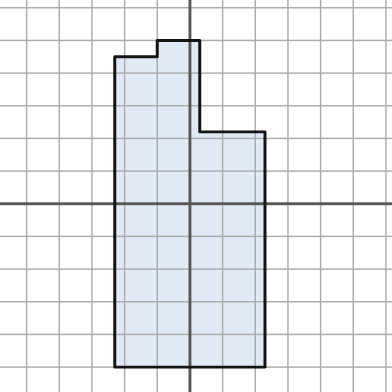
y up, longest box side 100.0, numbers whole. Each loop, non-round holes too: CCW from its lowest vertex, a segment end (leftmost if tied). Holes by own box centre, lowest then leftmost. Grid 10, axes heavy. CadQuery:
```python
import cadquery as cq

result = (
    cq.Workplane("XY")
    .moveTo(-23.0, -50.0)
    .lineTo(23.0, -50.0)
    .lineTo(23.0, 22.0)
    .lineTo(3.0, 22.0)
    .lineTo(3.0, 50.0)
    .lineTo(-10.0, 50.0)
    .lineTo(-10.0, 45.0)
    .lineTo(-23.0, 45.0)
    .close()
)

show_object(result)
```